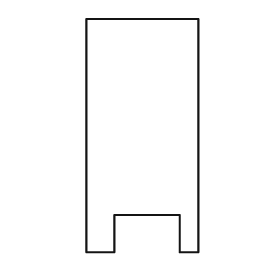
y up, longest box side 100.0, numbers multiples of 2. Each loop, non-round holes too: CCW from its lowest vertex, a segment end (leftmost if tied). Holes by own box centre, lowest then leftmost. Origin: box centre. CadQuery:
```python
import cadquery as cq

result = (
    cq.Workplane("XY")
    .moveTo(-24.0, -50.0)
    .lineTo(-12.0, -50.0)
    .lineTo(-12.0, -34.0)
    .lineTo(16.0, -34.0)
    .lineTo(16.0, -50.0)
    .lineTo(24.0, -50.0)
    .lineTo(24.0, 50.0)
    .lineTo(-24.0, 50.0)
    .close()
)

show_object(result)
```